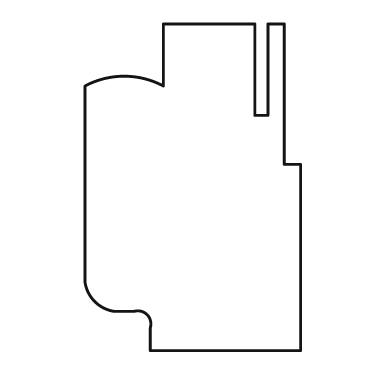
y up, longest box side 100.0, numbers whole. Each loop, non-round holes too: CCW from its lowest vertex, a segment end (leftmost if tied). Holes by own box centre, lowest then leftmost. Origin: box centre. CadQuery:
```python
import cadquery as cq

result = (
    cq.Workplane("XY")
    .moveTo(-13.0, -50.0)
    .lineTo(33.0, -50.0)
    .lineTo(33.0, 7.0)
    .lineTo(28.0, 7.0)
    .lineTo(28.0, 50.0)
    .lineTo(23.0, 50.0)
    .lineTo(23.0, 22.0)
    .lineTo(19.0, 22.0)
    .lineTo(19.0, 50.0)
    .lineTo(-9.0, 50.0)
    .lineTo(-9.0, 31.0)
    .threePointArc((-21.0, 34.0), (-33.0, 31.0))
    .lineTo(-33.0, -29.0)
    .threePointArc((-30.0, -35.0), (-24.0, -38.0))
    .lineTo(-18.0, -38.0)
    .threePointArc((-14.0, -39.0), (-13.0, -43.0))
    .close()
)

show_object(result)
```